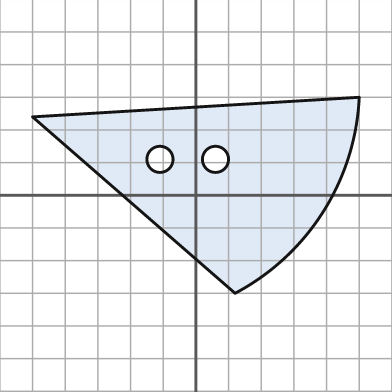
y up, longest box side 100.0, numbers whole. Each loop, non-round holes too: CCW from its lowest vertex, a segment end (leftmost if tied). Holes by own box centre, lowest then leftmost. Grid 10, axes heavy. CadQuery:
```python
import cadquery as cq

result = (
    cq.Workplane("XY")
    .moveTo(12.0, -30.0)
    .threePointArc((39.0, -5.0), (50.0, 30.0))
    .lineTo(-50.0, 24.0)
    .close()
    .moveTo(-11.0, 11.0)
    .circle(4.0)
    .moveTo(6.0, 11.0)
    .circle(4.0)
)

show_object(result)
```